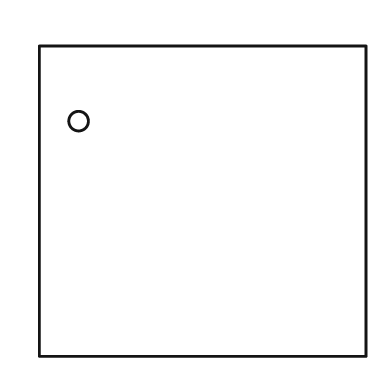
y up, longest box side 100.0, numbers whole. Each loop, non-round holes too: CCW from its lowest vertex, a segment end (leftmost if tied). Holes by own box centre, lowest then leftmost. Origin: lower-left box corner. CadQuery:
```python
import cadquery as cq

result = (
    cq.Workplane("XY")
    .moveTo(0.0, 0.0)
    .lineTo(100.0, 0.0)
    .lineTo(100.0, 95.0)
    .lineTo(0.0, 95.0)
    .close()
    .moveTo(12.0, 72.0)
    .circle(3.0)
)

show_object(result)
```